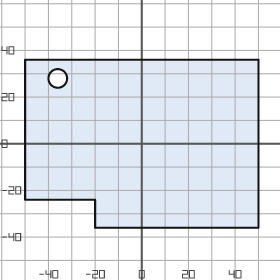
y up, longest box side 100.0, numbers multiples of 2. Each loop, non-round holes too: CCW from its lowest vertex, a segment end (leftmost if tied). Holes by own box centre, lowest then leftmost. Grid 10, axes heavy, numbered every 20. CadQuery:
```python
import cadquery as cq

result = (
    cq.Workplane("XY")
    .moveTo(-20.0, -36.0)
    .lineTo(50.0, -36.0)
    .lineTo(50.0, 36.0)
    .lineTo(-50.0, 36.0)
    .lineTo(-50.0, -24.0)
    .lineTo(-20.0, -24.0)
    .close()
    .moveTo(-36.0, 28.0)
    .circle(4.0)
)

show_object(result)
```